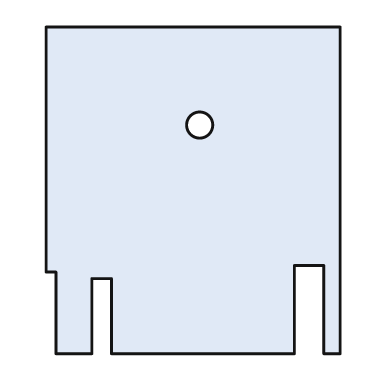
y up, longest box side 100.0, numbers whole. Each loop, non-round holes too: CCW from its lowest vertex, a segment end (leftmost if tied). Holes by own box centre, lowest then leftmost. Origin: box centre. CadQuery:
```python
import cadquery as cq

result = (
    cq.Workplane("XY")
    .moveTo(-42.0, -50.0)
    .lineTo(-31.0, -50.0)
    .lineTo(-31.0, -27.0)
    .lineTo(-25.0, -27.0)
    .lineTo(-25.0, -50.0)
    .lineTo(31.0, -50.0)
    .lineTo(31.0, -23.0)
    .lineTo(40.0, -23.0)
    .lineTo(40.0, -50.0)
    .lineTo(45.0, -50.0)
    .lineTo(45.0, 50.0)
    .lineTo(-45.0, 50.0)
    .lineTo(-45.0, -25.0)
    .lineTo(-42.0, -25.0)
    .close()
    .moveTo(2.0, 20.0)
    .circle(4.0)
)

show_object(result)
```